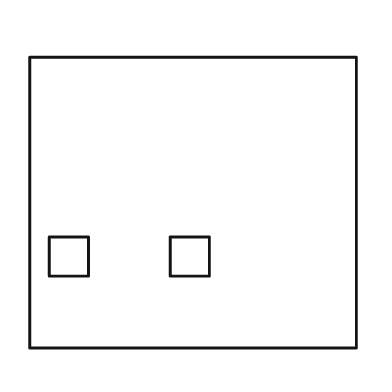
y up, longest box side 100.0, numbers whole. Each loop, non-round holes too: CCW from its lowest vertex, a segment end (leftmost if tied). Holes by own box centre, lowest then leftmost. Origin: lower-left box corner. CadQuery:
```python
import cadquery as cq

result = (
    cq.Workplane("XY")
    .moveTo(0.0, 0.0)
    .lineTo(100.0, 0.0)
    .lineTo(100.0, 89.0)
    .lineTo(0.0, 89.0)
    .close()
    .moveTo(6.0, 22.0)
    .lineTo(18.0, 22.0)
    .lineTo(18.0, 34.0)
    .lineTo(6.0, 34.0)
    .close()
    .moveTo(43.0, 22.0)
    .lineTo(55.0, 22.0)
    .lineTo(55.0, 34.0)
    .lineTo(43.0, 34.0)
    .close()
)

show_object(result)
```